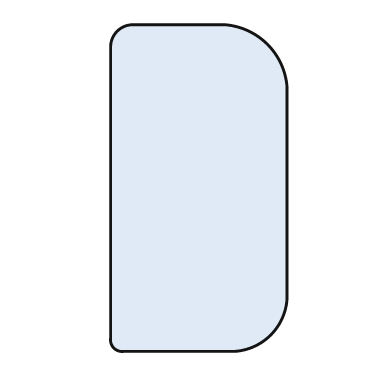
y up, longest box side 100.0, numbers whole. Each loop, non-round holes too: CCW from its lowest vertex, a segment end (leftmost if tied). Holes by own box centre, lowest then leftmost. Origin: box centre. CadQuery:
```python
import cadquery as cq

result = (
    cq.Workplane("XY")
    .moveTo(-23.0, -50.0)
    .lineTo(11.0, -50.0)
    .threePointArc((22.0, -45.0), (27.0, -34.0))
    .lineTo(27.0, 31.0)
    .threePointArc((21.0, 44.0), (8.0, 50.0))
    .lineTo(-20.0, 50.0)
    .threePointArc((-25.0, 48.0), (-27.0, 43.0))
    .lineTo(-27.0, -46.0)
    .threePointArc((-26.0, -49.0), (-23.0, -50.0))
    .close()
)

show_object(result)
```